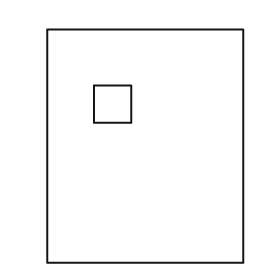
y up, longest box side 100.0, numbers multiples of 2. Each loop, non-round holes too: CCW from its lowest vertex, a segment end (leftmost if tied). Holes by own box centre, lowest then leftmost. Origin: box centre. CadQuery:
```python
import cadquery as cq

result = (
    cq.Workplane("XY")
    .moveTo(-42.0, -50.0)
    .lineTo(42.0, -50.0)
    .lineTo(42.0, 50.0)
    .lineTo(-42.0, 50.0)
    .close()
    .moveTo(-22.0, 10.0)
    .lineTo(-6.0, 10.0)
    .lineTo(-6.0, 26.0)
    .lineTo(-22.0, 26.0)
    .close()
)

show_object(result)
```